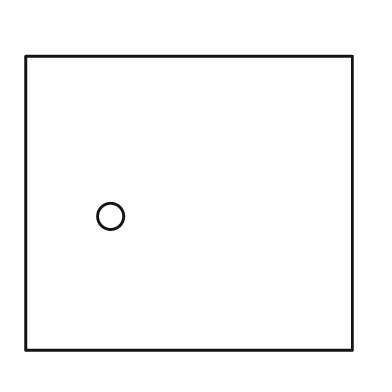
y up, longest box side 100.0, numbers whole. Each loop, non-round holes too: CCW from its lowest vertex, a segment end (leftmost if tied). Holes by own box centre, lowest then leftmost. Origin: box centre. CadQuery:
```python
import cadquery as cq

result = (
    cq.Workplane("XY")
    .moveTo(-50.0, -45.0)
    .lineTo(50.0, -45.0)
    .lineTo(50.0, 45.0)
    .lineTo(-50.0, 45.0)
    .close()
    .moveTo(-24.0, -4.0)
    .circle(4.0)
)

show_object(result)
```